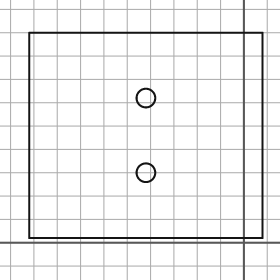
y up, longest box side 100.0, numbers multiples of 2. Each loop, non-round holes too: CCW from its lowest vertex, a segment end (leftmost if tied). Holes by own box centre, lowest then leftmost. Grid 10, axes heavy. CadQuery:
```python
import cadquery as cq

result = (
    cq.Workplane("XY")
    .moveTo(-92.0, 2.0)
    .lineTo(8.0, 2.0)
    .lineTo(8.0, 90.0)
    .lineTo(-92.0, 90.0)
    .close()
    .moveTo(-42.0, 30.0)
    .circle(4.0)
    .moveTo(-42.0, 62.0)
    .circle(4.0)
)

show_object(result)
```